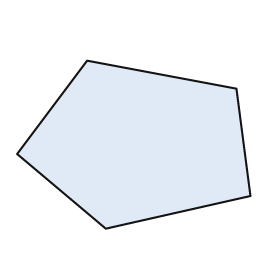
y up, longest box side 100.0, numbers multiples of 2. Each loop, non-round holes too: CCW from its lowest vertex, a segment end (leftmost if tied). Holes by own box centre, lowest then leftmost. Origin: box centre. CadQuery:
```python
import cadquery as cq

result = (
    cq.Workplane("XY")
    .moveTo(-12.0, -36.0)
    .lineTo(50.0, -22.0)
    .lineTo(44.0, 24.0)
    .lineTo(-20.0, 36.0)
    .lineTo(-50.0, -4.0)
    .close()
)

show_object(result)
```